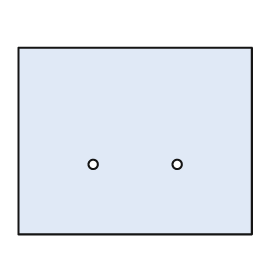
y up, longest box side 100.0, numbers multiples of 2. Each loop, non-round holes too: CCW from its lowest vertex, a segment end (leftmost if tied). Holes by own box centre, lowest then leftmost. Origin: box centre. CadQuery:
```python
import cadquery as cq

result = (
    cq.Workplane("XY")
    .moveTo(-50.0, -40.0)
    .lineTo(50.0, -40.0)
    .lineTo(50.0, 40.0)
    .lineTo(-50.0, 40.0)
    .close()
    .moveTo(-18.0, -10.0)
    .circle(2.0)
    .moveTo(18.0, -10.0)
    .circle(2.0)
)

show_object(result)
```